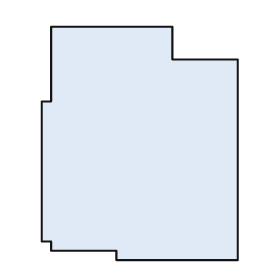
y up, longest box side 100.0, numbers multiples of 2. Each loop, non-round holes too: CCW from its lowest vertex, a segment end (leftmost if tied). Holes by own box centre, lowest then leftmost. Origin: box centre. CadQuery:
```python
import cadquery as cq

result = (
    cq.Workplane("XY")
    .moveTo(-10.0, -50.0)
    .lineTo(42.0, -50.0)
    .lineTo(42.0, 36.0)
    .lineTo(14.0, 36.0)
    .lineTo(14.0, 50.0)
    .lineTo(-38.0, 50.0)
    .lineTo(-38.0, 18.0)
    .lineTo(-42.0, 18.0)
    .lineTo(-42.0, -42.0)
    .lineTo(-38.0, -42.0)
    .lineTo(-38.0, -46.0)
    .lineTo(-10.0, -46.0)
    .close()
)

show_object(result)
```